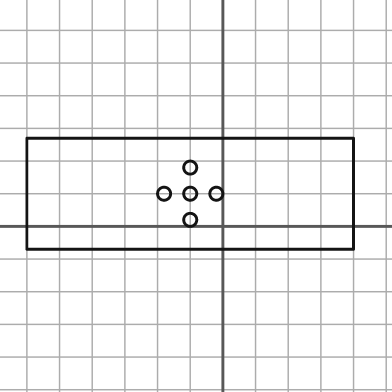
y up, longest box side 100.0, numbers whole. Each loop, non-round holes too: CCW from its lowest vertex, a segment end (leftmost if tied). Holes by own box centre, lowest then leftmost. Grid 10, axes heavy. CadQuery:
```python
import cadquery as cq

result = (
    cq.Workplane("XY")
    .moveTo(-60.0, -7.0)
    .lineTo(40.0, -7.0)
    .lineTo(40.0, 27.0)
    .lineTo(-60.0, 27.0)
    .close()
    .moveTo(-10.0, 2.0)
    .circle(2.0)
    .moveTo(-18.0, 10.0)
    .circle(2.0)
    .moveTo(-10.0, 10.0)
    .circle(2.0)
    .moveTo(-2.0, 10.0)
    .circle(2.0)
    .moveTo(-10.0, 18.0)
    .circle(2.0)
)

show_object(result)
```